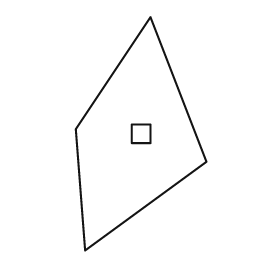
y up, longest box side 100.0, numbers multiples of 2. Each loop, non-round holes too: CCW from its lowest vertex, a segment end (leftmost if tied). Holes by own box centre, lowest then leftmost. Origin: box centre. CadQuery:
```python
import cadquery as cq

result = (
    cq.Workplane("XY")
    .moveTo(-24.0, -50.0)
    .lineTo(28.0, -12.0)
    .lineTo(4.0, 50.0)
    .lineTo(-28.0, 2.0)
    .close()
    .moveTo(-4.0, -4.0)
    .lineTo(4.0, -4.0)
    .lineTo(4.0, 4.0)
    .lineTo(-4.0, 4.0)
    .close()
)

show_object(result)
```